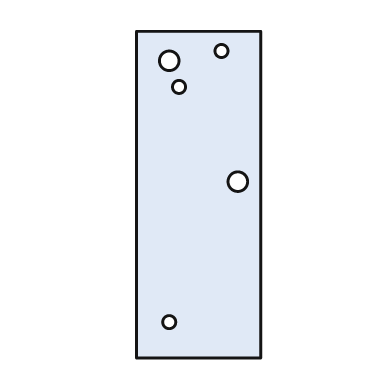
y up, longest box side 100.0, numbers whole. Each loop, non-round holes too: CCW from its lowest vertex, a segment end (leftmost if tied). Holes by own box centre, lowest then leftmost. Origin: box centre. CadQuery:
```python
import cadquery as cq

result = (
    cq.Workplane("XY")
    .moveTo(-19.0, -50.0)
    .lineTo(19.0, -50.0)
    .lineTo(19.0, 50.0)
    .lineTo(-19.0, 50.0)
    .close()
    .moveTo(-9.0, -39.0)
    .circle(2.0)
    .moveTo(12.0, 4.0)
    .circle(3.0)
    .moveTo(-6.0, 33.0)
    .circle(2.0)
    .moveTo(-9.0, 41.0)
    .circle(3.0)
    .moveTo(7.0, 44.0)
    .circle(2.0)
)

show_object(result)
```